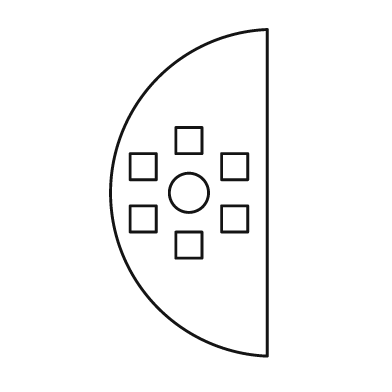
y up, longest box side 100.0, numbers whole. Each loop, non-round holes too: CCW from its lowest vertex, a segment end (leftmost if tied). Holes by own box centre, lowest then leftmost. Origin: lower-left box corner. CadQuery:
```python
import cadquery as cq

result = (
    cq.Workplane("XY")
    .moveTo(48.0, 0.0)
    .lineTo(48.0, 100.0)
    .threePointArc((0.0, 50.0), (48.0, 0.0))
    .close()
    .moveTo(20.0, 30.0)
    .lineTo(28.0, 30.0)
    .lineTo(28.0, 38.0)
    .lineTo(20.0, 38.0)
    .close()
    .moveTo(6.0, 38.0)
    .lineTo(14.0, 38.0)
    .lineTo(14.0, 46.0)
    .lineTo(6.0, 46.0)
    .close()
    .moveTo(34.0, 38.0)
    .lineTo(42.0, 38.0)
    .lineTo(42.0, 46.0)
    .lineTo(34.0, 46.0)
    .close()
    .moveTo(24.0, 50.0)
    .circle(6.0)
    .moveTo(6.0, 54.0)
    .lineTo(14.0, 54.0)
    .lineTo(14.0, 62.0)
    .lineTo(6.0, 62.0)
    .close()
    .moveTo(34.0, 54.0)
    .lineTo(42.0, 54.0)
    .lineTo(42.0, 62.0)
    .lineTo(34.0, 62.0)
    .close()
    .moveTo(20.0, 62.0)
    .lineTo(28.0, 62.0)
    .lineTo(28.0, 70.0)
    .lineTo(20.0, 70.0)
    .close()
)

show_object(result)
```